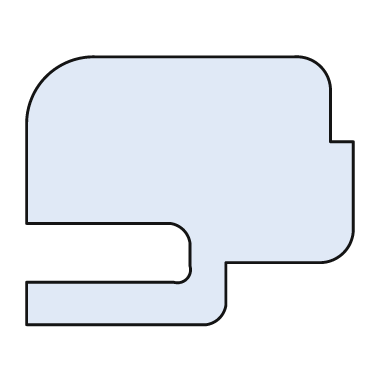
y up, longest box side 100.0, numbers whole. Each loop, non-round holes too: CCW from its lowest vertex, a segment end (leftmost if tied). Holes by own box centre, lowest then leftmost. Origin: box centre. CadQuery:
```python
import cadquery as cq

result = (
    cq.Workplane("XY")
    .moveTo(-50.0, -41.0)
    .lineTo(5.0, -41.0)
    .threePointArc((9.0, -39.0), (11.0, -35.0))
    .lineTo(11.0, -22.0)
    .lineTo(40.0, -22.0)
    .threePointArc((47.0, -19.0), (50.0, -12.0))
    .lineTo(50.0, 15.0)
    .lineTo(43.0, 15.0)
    .lineTo(43.0, 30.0)
    .threePointArc((40.0, 38.0), (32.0, 41.0))
    .lineTo(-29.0, 41.0)
    .threePointArc((-44.0, 35.0), (-50.0, 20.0))
    .lineTo(-50.0, -10.0)
    .lineTo(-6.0, -10.0)
    .threePointArc((-2.0, -12.0), (0.0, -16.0))
    .lineTo(0.0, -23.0)
    .threePointArc((-1.0, -27.0), (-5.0, -28.0))
    .lineTo(-50.0, -28.0)
    .close()
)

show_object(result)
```